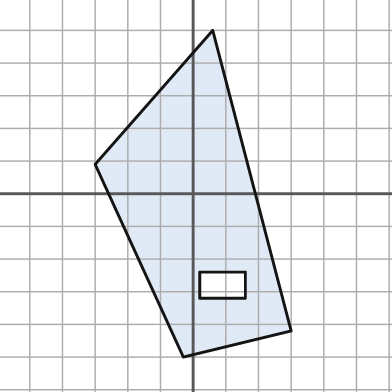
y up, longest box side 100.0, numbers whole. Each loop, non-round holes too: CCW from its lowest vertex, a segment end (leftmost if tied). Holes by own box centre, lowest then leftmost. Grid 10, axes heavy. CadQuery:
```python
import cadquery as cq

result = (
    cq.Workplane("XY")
    .moveTo(-3.0, -50.0)
    .lineTo(30.0, -42.0)
    .lineTo(6.0, 50.0)
    .lineTo(-30.0, 9.0)
    .close()
    .moveTo(2.0, -32.0)
    .lineTo(16.0, -32.0)
    .lineTo(16.0, -24.0)
    .lineTo(2.0, -24.0)
    .close()
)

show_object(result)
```